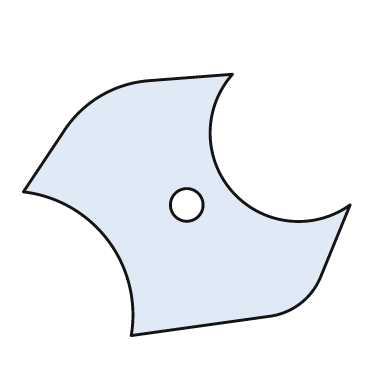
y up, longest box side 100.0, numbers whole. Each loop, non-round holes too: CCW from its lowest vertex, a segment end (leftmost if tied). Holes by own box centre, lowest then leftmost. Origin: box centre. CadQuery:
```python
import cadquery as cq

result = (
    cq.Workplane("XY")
    .moveTo(-17.0, -40.0)
    .lineTo(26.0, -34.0)
    .threePointArc((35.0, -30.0), (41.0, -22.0))
    .lineTo(50.0, 0.0)
    .threePointArc((14.0, 4.0), (14.0, 40.0))
    .lineTo(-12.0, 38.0)
    .threePointArc((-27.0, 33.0), (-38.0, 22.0))
    .lineTo(-50.0, 4.0)
    .threePointArc((-24.0, -11.0), (-17.0, -40.0))
    .close()
    .moveTo(0.0, 0.0)
    .circle(5.0)
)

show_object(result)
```